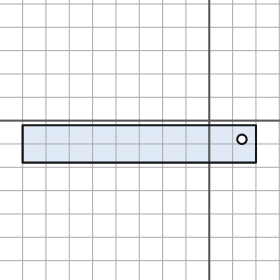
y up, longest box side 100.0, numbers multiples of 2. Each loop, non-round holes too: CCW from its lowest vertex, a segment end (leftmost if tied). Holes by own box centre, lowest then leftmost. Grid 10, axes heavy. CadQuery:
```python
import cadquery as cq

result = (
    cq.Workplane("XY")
    .moveTo(-80.0, -18.0)
    .lineTo(20.0, -18.0)
    .lineTo(20.0, -2.0)
    .lineTo(-80.0, -2.0)
    .close()
    .moveTo(14.0, -8.0)
    .circle(2.0)
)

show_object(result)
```